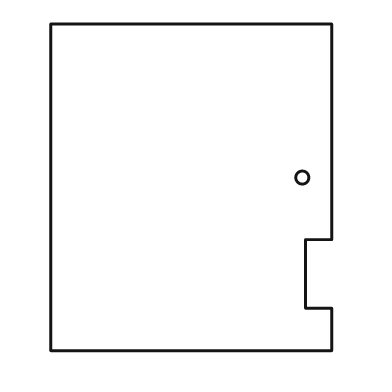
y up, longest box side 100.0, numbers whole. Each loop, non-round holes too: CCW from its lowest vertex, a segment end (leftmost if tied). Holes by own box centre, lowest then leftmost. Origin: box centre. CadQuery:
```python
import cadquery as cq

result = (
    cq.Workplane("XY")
    .moveTo(-43.0, -50.0)
    .lineTo(43.0, -50.0)
    .lineTo(43.0, -37.0)
    .lineTo(35.0, -37.0)
    .lineTo(35.0, -16.0)
    .lineTo(43.0, -16.0)
    .lineTo(43.0, 50.0)
    .lineTo(-43.0, 50.0)
    .close()
    .moveTo(34.0, 3.0)
    .circle(2.0)
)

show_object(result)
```